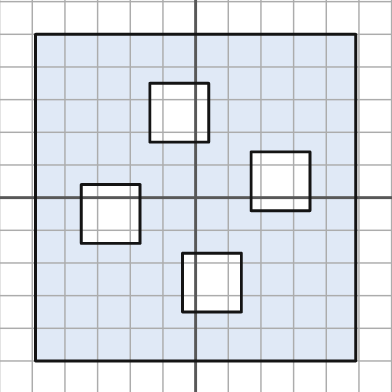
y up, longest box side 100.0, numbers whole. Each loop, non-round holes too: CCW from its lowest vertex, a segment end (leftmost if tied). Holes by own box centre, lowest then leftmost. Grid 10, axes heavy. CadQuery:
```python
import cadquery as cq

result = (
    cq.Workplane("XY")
    .moveTo(-49.0, -50.0)
    .lineTo(49.0, -50.0)
    .lineTo(49.0, 50.0)
    .lineTo(-49.0, 50.0)
    .close()
    .moveTo(-4.0, -35.0)
    .lineTo(14.0, -35.0)
    .lineTo(14.0, -17.0)
    .lineTo(-4.0, -17.0)
    .close()
    .moveTo(-35.0, -14.0)
    .lineTo(-17.0, -14.0)
    .lineTo(-17.0, 4.0)
    .lineTo(-35.0, 4.0)
    .close()
    .moveTo(17.0, -4.0)
    .lineTo(35.0, -4.0)
    .lineTo(35.0, 14.0)
    .lineTo(17.0, 14.0)
    .close()
    .moveTo(-14.0, 17.0)
    .lineTo(4.0, 17.0)
    .lineTo(4.0, 35.0)
    .lineTo(-14.0, 35.0)
    .close()
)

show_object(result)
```